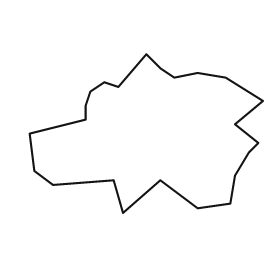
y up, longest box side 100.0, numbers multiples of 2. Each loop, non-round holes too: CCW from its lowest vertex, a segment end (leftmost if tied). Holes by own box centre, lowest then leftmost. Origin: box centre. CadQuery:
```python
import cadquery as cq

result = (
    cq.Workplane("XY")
    .moveTo(-10.0, -34.0)
    .lineTo(6.0, -20.0)
    .lineTo(22.0, -32.0)
    .lineTo(36.0, -30.0)
    .lineTo(38.0, -18.0)
    .lineTo(44.0, -8.0)
    .lineTo(48.0, -4.0)
    .lineTo(38.0, 4.0)
    .lineTo(50.0, 14.0)
    .lineTo(34.0, 24.0)
    .lineTo(22.0, 26.0)
    .lineTo(12.0, 24.0)
    .lineTo(6.0, 28.0)
    .lineTo(0.0, 34.0)
    .lineTo(-12.0, 20.0)
    .lineTo(-18.0, 22.0)
    .lineTo(-24.0, 18.0)
    .lineTo(-26.0, 12.0)
    .lineTo(-26.0, 6.0)
    .lineTo(-50.0, 0.0)
    .lineTo(-48.0, -16.0)
    .lineTo(-40.0, -22.0)
    .lineTo(-14.0, -20.0)
    .close()
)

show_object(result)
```